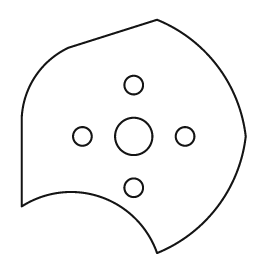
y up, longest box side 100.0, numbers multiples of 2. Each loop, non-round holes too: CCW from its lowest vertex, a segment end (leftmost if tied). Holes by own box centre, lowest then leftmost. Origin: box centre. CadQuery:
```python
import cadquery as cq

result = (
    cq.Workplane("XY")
    .moveTo(10.0, -50.0)
    .threePointArc((36.0, -30.0), (48.0, 0.0))
    .threePointArc((36.0, 30.0), (10.0, 50.0))
    .lineTo(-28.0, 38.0)
    .threePointArc((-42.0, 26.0), (-48.0, 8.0))
    .lineTo(-48.0, -30.0)
    .threePointArc((-14.0, -26.0), (10.0, -50.0))
    .close()
    .moveTo(0.0, -22.0)
    .circle(4.0)
    .moveTo(-22.0, 0.0)
    .circle(4.0)
    .moveTo(0.0, 0.0)
    .circle(8.0)
    .moveTo(22.0, 0.0)
    .circle(4.0)
    .moveTo(0.0, 22.0)
    .circle(4.0)
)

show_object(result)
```